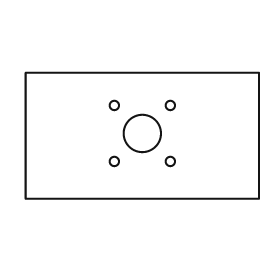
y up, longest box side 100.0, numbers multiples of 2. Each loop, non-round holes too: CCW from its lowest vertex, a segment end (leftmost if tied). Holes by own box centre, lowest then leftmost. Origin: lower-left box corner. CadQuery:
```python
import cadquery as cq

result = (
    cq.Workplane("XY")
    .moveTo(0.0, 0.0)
    .lineTo(100.0, 0.0)
    .lineTo(100.0, 54.0)
    .lineTo(0.0, 54.0)
    .close()
    .moveTo(38.0, 16.0)
    .circle(2.0)
    .moveTo(62.0, 16.0)
    .circle(2.0)
    .moveTo(50.0, 28.0)
    .circle(8.0)
    .moveTo(38.0, 40.0)
    .circle(2.0)
    .moveTo(62.0, 40.0)
    .circle(2.0)
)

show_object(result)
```